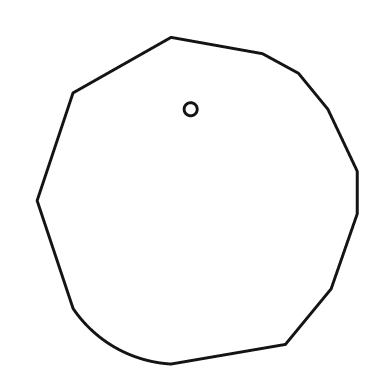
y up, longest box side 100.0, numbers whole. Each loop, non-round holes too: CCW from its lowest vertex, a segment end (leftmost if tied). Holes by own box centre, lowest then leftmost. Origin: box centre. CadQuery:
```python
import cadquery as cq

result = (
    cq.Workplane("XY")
    .moveTo(-8.0, -50.0)
    .lineTo(27.0, -44.0)
    .lineTo(41.0, -27.0)
    .lineTo(49.0, -4.0)
    .lineTo(49.0, 9.0)
    .lineTo(40.0, 28.0)
    .lineTo(31.0, 39.0)
    .lineTo(20.0, 45.0)
    .lineTo(-8.0, 50.0)
    .lineTo(-38.0, 33.0)
    .lineTo(-49.0, 0.0)
    .lineTo(-38.0, -33.0)
    .threePointArc((-25.0, -45.0), (-8.0, -50.0))
    .close()
    .moveTo(-2.0, 28.0)
    .circle(2.0)
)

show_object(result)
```